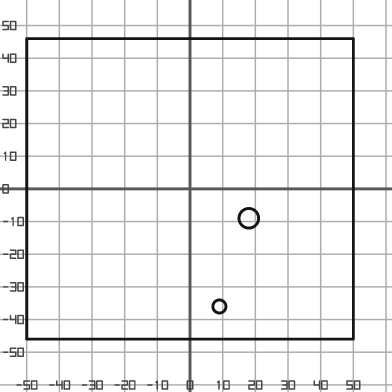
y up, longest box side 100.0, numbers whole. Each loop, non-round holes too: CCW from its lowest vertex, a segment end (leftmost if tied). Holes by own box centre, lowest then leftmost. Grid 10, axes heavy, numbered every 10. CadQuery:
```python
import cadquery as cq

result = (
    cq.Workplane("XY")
    .moveTo(-50.0, -46.0)
    .lineTo(50.0, -46.0)
    .lineTo(50.0, 46.0)
    .lineTo(-50.0, 46.0)
    .close()
    .moveTo(9.0, -36.0)
    .circle(2.0)
    .moveTo(18.0, -9.0)
    .circle(3.0)
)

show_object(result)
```